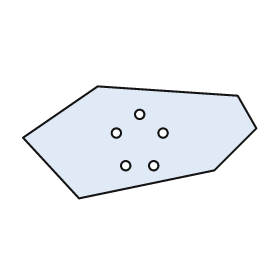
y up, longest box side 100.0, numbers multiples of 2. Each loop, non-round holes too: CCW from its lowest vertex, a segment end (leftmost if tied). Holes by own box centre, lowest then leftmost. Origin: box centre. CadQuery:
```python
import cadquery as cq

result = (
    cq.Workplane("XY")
    .moveTo(-26.0, -24.0)
    .lineTo(32.0, -12.0)
    .lineTo(50.0, 6.0)
    .lineTo(42.0, 20.0)
    .lineTo(-18.0, 24.0)
    .lineTo(-50.0, 2.0)
    .close()
    .moveTo(-6.0, -10.0)
    .circle(2.0)
    .moveTo(6.0, -10.0)
    .circle(2.0)
    .moveTo(-10.0, 4.0)
    .circle(2.0)
    .moveTo(10.0, 4.0)
    .circle(2.0)
    .moveTo(0.0, 12.0)
    .circle(2.0)
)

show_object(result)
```